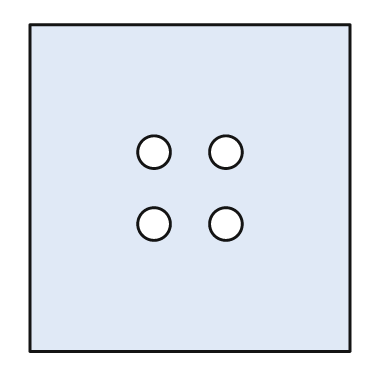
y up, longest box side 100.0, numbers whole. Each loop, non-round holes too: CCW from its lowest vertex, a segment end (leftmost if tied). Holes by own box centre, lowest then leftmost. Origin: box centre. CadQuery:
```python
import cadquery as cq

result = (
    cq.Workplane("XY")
    .moveTo(-49.0, -50.0)
    .lineTo(49.0, -50.0)
    .lineTo(49.0, 50.0)
    .lineTo(-49.0, 50.0)
    .close()
    .moveTo(-11.0, -11.0)
    .circle(5.0)
    .moveTo(11.0, -11.0)
    .circle(5.0)
    .moveTo(-11.0, 11.0)
    .circle(5.0)
    .moveTo(11.0, 11.0)
    .circle(5.0)
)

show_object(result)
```